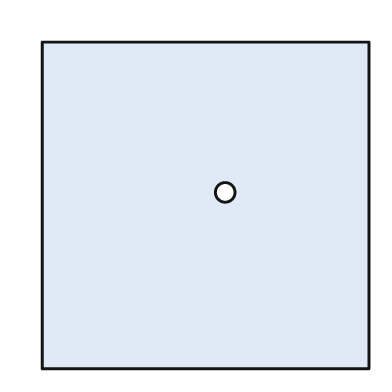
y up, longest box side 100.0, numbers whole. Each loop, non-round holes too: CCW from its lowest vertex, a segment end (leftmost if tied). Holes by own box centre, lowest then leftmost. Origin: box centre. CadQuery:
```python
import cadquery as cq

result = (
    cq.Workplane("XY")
    .moveTo(-50.0, -50.0)
    .lineTo(50.0, -50.0)
    .lineTo(50.0, 50.0)
    .lineTo(-50.0, 50.0)
    .close()
    .moveTo(6.0, 4.0)
    .circle(3.0)
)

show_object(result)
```